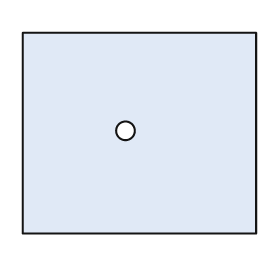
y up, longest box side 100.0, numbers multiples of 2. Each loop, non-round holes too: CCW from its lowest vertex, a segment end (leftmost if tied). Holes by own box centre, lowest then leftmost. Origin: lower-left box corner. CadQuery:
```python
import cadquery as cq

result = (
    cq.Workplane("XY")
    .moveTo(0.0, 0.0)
    .lineTo(100.0, 0.0)
    .lineTo(100.0, 86.0)
    .lineTo(0.0, 86.0)
    .close()
    .moveTo(44.0, 44.0)
    .circle(4.0)
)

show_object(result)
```